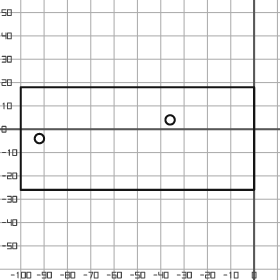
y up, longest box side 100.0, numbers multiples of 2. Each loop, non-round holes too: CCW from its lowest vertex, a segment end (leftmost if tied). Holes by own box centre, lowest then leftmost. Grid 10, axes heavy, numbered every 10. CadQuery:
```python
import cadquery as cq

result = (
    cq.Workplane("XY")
    .moveTo(-100.0, -26.0)
    .lineTo(0.0, -26.0)
    .lineTo(0.0, 18.0)
    .lineTo(-100.0, 18.0)
    .close()
    .moveTo(-92.0, -4.0)
    .circle(2.0)
    .moveTo(-36.0, 4.0)
    .circle(2.0)
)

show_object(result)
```